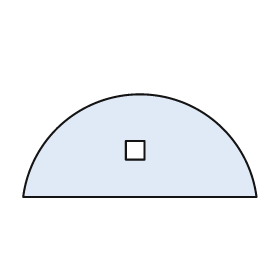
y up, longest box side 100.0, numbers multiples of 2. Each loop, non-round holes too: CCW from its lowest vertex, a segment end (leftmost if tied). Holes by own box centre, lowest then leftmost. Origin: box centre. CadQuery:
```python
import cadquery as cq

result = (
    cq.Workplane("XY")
    .moveTo(-50.0, -22.0)
    .lineTo(50.0, -22.0)
    .threePointArc((0.0, 22.0), (-50.0, -22.0))
    .close()
    .moveTo(-6.0, -6.0)
    .lineTo(2.0, -6.0)
    .lineTo(2.0, 2.0)
    .lineTo(-6.0, 2.0)
    .close()
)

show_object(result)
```